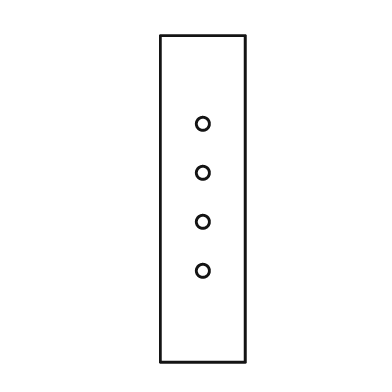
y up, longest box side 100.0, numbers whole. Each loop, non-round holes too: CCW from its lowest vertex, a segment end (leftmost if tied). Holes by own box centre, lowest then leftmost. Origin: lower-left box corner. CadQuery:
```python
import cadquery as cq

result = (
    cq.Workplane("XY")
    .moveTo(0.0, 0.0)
    .lineTo(26.0, 0.0)
    .lineTo(26.0, 100.0)
    .lineTo(0.0, 100.0)
    .close()
    .moveTo(13.0, 28.0)
    .circle(2.0)
    .moveTo(13.0, 43.0)
    .circle(2.0)
    .moveTo(13.0, 58.0)
    .circle(2.0)
    .moveTo(13.0, 73.0)
    .circle(2.0)
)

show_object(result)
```